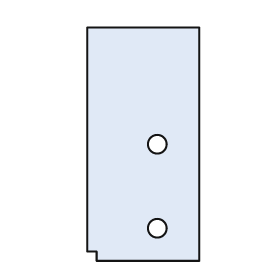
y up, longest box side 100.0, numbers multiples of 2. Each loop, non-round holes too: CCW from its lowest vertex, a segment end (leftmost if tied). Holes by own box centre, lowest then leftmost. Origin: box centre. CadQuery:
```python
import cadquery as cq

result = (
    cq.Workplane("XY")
    .moveTo(-20.0, -50.0)
    .lineTo(24.0, -50.0)
    .lineTo(24.0, 50.0)
    .lineTo(-24.0, 50.0)
    .lineTo(-24.0, -46.0)
    .lineTo(-20.0, -46.0)
    .close()
    .moveTo(6.0, -36.0)
    .circle(4.0)
    .moveTo(6.0, 0.0)
    .circle(4.0)
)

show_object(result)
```